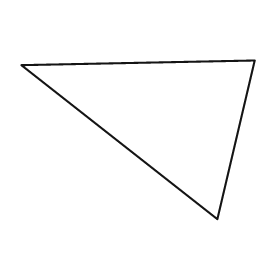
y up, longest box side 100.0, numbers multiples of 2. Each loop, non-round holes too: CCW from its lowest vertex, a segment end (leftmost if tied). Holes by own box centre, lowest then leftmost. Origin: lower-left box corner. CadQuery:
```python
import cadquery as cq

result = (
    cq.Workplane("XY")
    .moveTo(84.0, 0.0)
    .lineTo(100.0, 68.0)
    .lineTo(0.0, 66.0)
    .close()
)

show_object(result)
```